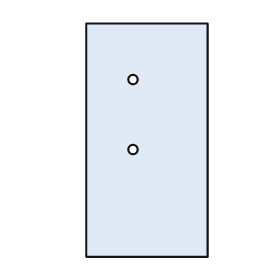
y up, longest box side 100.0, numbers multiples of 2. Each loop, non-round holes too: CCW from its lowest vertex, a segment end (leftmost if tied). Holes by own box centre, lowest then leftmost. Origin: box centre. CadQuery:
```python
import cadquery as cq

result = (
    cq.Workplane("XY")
    .moveTo(-26.0, -50.0)
    .lineTo(26.0, -50.0)
    .lineTo(26.0, 50.0)
    .lineTo(-26.0, 50.0)
    .close()
    .moveTo(-6.0, -4.0)
    .circle(2.0)
    .moveTo(-6.0, 26.0)
    .circle(2.0)
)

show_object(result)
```